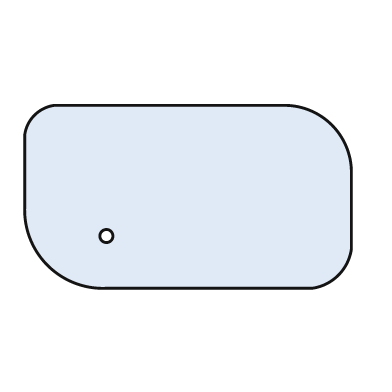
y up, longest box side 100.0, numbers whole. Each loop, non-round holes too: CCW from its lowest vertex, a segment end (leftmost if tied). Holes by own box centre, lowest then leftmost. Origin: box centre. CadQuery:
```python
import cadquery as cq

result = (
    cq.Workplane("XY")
    .moveTo(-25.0, -28.0)
    .lineTo(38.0, -28.0)
    .threePointArc((46.0, -24.0), (50.0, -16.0))
    .lineTo(50.0, 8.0)
    .threePointArc((44.0, 22.0), (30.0, 28.0))
    .lineTo(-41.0, 28.0)
    .threePointArc((-47.0, 25.0), (-50.0, 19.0))
    .lineTo(-50.0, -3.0)
    .threePointArc((-43.0, -21.0), (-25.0, -28.0))
    .close()
    .moveTo(-25.0, -12.0)
    .circle(2.0)
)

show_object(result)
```